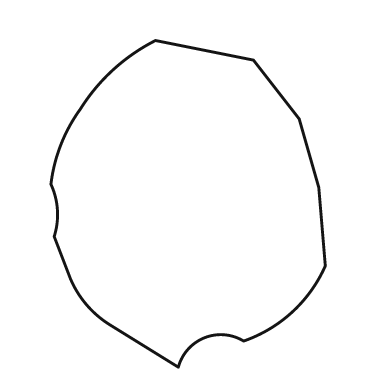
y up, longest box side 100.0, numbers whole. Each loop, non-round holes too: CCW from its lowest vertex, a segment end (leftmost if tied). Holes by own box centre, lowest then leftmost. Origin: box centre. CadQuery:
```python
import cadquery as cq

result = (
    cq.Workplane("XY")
    .moveTo(-3.0, -50.0)
    .threePointArc((5.0, -41.0), (17.0, -42.0))
    .threePointArc((32.0, -33.0), (42.0, -19.0))
    .lineTo(40.0, 5.0)
    .lineTo(34.0, 26.0)
    .lineTo(20.0, 44.0)
    .lineTo(-10.0, 50.0)
    .threePointArc((-23.0, 41.0), (-33.0, 29.0))
    .threePointArc((-39.0, 18.0), (-42.0, 6.0))
    .threePointArc((-40.0, -2.0), (-41.0, -10.0))
    .lineTo(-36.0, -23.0)
    .threePointArc((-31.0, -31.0), (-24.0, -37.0))
    .close()
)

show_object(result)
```